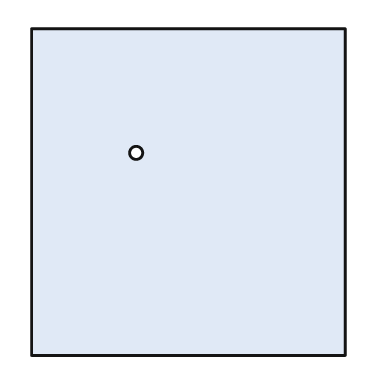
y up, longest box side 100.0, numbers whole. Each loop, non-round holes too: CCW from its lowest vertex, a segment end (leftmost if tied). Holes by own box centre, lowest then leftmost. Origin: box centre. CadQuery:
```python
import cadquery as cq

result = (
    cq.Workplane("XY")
    .moveTo(-48.0, -50.0)
    .lineTo(48.0, -50.0)
    .lineTo(48.0, 50.0)
    .lineTo(-48.0, 50.0)
    .close()
    .moveTo(-16.0, 12.0)
    .circle(2.0)
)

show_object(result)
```